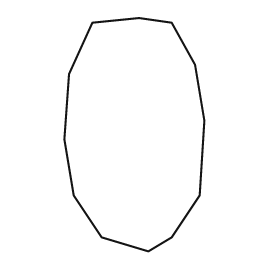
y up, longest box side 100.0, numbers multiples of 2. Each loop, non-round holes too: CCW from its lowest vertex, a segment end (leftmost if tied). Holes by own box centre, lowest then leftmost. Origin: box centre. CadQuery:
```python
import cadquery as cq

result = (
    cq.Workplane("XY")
    .moveTo(6.0, -50.0)
    .lineTo(16.0, -44.0)
    .lineTo(28.0, -26.0)
    .lineTo(30.0, 6.0)
    .lineTo(26.0, 30.0)
    .lineTo(16.0, 48.0)
    .lineTo(2.0, 50.0)
    .lineTo(-18.0, 48.0)
    .lineTo(-28.0, 26.0)
    .lineTo(-30.0, -2.0)
    .lineTo(-26.0, -26.0)
    .lineTo(-14.0, -44.0)
    .close()
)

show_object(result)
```